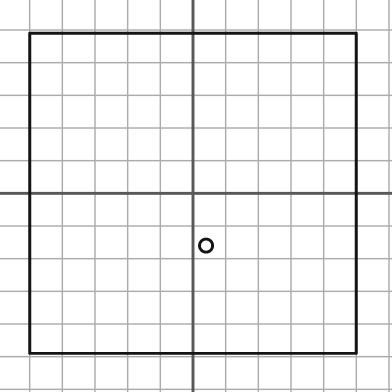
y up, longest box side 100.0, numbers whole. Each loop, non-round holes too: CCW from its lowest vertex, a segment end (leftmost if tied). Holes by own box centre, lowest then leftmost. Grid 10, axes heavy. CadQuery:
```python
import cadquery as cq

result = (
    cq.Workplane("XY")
    .moveTo(-50.0, -49.0)
    .lineTo(50.0, -49.0)
    .lineTo(50.0, 49.0)
    .lineTo(-50.0, 49.0)
    .close()
    .moveTo(4.0, -16.0)
    .circle(2.0)
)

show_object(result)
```